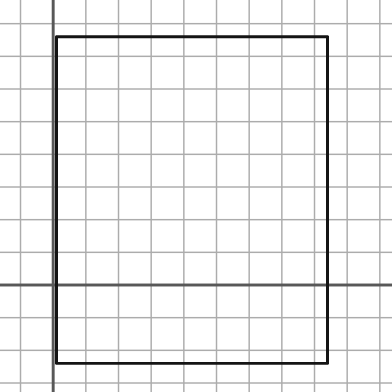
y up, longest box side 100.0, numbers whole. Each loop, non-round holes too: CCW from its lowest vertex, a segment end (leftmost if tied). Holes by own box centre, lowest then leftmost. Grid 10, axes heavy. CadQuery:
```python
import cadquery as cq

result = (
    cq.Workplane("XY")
    .moveTo(1.0, -24.0)
    .lineTo(84.0, -24.0)
    .lineTo(84.0, 76.0)
    .lineTo(1.0, 76.0)
    .close()
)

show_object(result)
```